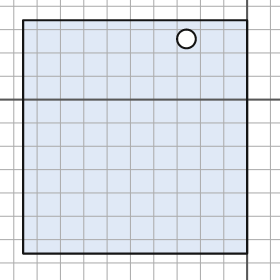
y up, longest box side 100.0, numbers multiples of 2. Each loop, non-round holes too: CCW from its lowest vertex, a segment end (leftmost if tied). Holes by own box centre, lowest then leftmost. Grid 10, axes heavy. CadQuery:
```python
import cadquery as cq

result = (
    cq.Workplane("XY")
    .moveTo(-96.0, -66.0)
    .lineTo(0.0, -66.0)
    .lineTo(0.0, 34.0)
    .lineTo(-96.0, 34.0)
    .close()
    .moveTo(-26.0, 26.0)
    .circle(4.0)
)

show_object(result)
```